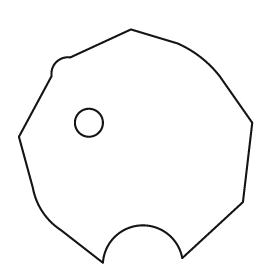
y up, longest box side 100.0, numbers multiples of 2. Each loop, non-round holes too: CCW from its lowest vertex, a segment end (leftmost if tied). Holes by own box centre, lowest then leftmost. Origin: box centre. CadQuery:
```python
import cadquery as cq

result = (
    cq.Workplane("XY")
    .moveTo(-14.0, -50.0)
    .threePointArc((2.0, -34.0), (20.0, -48.0))
    .lineTo(46.0, -24.0)
    .lineTo(50.0, 10.0)
    .lineTo(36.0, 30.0)
    .threePointArc((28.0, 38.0), (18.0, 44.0))
    .lineTo(-2.0, 50.0)
    .lineTo(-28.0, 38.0)
    .threePointArc((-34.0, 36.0), (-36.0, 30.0))
    .lineTo(-50.0, 4.0)
    .lineTo(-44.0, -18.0)
    .threePointArc((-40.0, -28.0), (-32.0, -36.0))
    .close()
    .moveTo(-20.0, 10.0)
    .circle(6.0)
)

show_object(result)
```